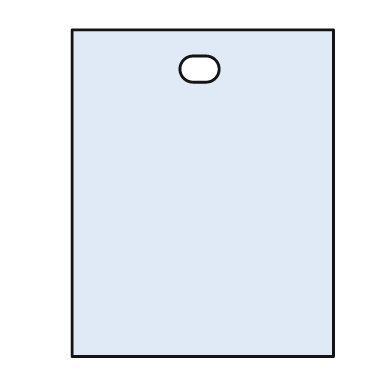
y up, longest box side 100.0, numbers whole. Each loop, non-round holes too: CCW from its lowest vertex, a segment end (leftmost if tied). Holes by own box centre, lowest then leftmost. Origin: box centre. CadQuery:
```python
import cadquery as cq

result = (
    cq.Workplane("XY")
    .moveTo(-40.0, -50.0)
    .lineTo(40.0, -50.0)
    .lineTo(40.0, 50.0)
    .lineTo(-40.0, 50.0)
    .close()
    .moveTo(-3.0, 34.0)
    .lineTo(1.0, 34.0)
    .threePointArc((5.0, 38.0), (1.0, 42.0))
    .lineTo(-3.0, 42.0)
    .threePointArc((-7.0, 38.0), (-3.0, 34.0))
    .close()
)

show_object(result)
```